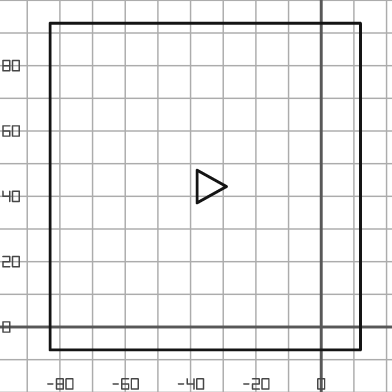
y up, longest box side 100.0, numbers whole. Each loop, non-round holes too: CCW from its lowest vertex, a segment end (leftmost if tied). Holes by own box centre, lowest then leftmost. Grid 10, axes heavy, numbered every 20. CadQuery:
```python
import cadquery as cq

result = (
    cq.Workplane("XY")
    .moveTo(-83.0, -7.0)
    .lineTo(12.0, -7.0)
    .lineTo(12.0, 93.0)
    .lineTo(-83.0, 93.0)
    .close()
    .moveTo(-38.0, 38.0)
    .lineTo(-29.0, 43.0)
    .lineTo(-38.0, 48.0)
    .close()
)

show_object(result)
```